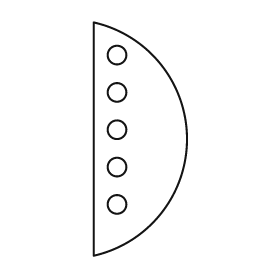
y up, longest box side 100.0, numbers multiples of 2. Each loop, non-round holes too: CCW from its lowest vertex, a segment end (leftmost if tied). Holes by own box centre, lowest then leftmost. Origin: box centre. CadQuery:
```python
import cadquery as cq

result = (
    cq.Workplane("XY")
    .moveTo(-20.0, -50.0)
    .threePointArc((20.0, 0.0), (-20.0, 50.0))
    .close()
    .moveTo(-10.0, -28.0)
    .circle(4.0)
    .moveTo(-10.0, -12.0)
    .circle(4.0)
    .moveTo(-10.0, 4.0)
    .circle(4.0)
    .moveTo(-10.0, 20.0)
    .circle(4.0)
    .moveTo(-10.0, 36.0)
    .circle(4.0)
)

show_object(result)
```